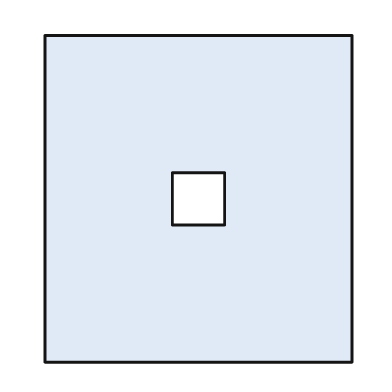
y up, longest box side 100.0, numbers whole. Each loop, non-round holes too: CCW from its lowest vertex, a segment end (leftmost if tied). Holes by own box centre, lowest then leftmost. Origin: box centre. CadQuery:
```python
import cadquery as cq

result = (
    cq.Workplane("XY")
    .moveTo(-47.0, -50.0)
    .lineTo(47.0, -50.0)
    .lineTo(47.0, 50.0)
    .lineTo(-47.0, 50.0)
    .close()
    .moveTo(-8.0, -8.0)
    .lineTo(8.0, -8.0)
    .lineTo(8.0, 8.0)
    .lineTo(-8.0, 8.0)
    .close()
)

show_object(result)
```